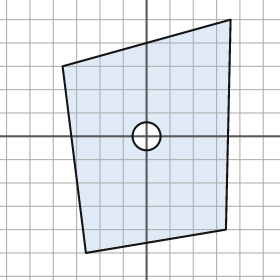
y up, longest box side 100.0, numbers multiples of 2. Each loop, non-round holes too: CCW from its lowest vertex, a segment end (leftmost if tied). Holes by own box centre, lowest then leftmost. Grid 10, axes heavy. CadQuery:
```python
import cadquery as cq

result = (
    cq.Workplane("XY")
    .moveTo(-26.0, -50.0)
    .lineTo(34.0, -40.0)
    .lineTo(36.0, 50.0)
    .lineTo(-36.0, 30.0)
    .close()
    .moveTo(0.0, 0.0)
    .circle(6.0)
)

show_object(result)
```